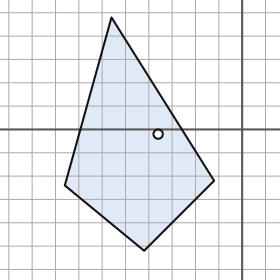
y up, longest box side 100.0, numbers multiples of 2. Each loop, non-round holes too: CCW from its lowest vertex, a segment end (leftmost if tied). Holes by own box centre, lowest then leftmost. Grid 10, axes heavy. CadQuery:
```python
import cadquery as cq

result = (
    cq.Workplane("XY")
    .moveTo(-42.0, -52.0)
    .lineTo(-12.0, -22.0)
    .lineTo(-56.0, 48.0)
    .lineTo(-76.0, -24.0)
    .close()
    .moveTo(-36.0, -2.0)
    .circle(2.0)
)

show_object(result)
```